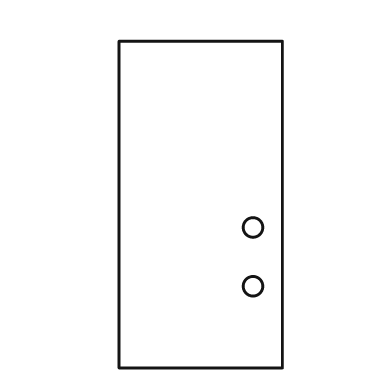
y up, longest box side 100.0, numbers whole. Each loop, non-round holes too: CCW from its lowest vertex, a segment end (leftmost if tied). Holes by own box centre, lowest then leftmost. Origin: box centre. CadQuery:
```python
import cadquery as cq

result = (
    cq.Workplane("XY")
    .moveTo(-25.0, -50.0)
    .lineTo(25.0, -50.0)
    .lineTo(25.0, 50.0)
    .lineTo(-25.0, 50.0)
    .close()
    .moveTo(16.0, -25.0)
    .circle(3.0)
    .moveTo(16.0, -7.0)
    .circle(3.0)
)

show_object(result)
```